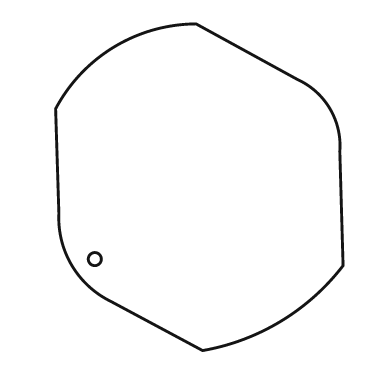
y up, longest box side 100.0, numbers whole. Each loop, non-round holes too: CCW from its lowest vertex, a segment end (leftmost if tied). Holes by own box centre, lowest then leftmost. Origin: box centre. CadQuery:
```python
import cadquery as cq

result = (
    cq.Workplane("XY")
    .moveTo(1.0, -50.0)
    .threePointArc((25.0, -41.0), (44.0, -24.0))
    .lineTo(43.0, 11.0)
    .threePointArc((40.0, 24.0), (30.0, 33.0))
    .lineTo(-1.0, 50.0)
    .threePointArc((-26.0, 43.0), (-44.0, 24.0))
    .lineTo(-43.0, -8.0)
    .threePointArc((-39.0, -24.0), (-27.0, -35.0))
    .close()
    .moveTo(-32.0, -22.0)
    .circle(2.0)
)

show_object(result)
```